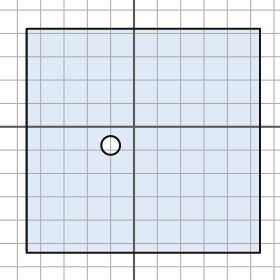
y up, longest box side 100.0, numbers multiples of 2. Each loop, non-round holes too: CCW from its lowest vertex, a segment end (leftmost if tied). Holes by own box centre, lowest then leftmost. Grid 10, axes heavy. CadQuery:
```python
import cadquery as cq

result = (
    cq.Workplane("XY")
    .moveTo(-46.0, -54.0)
    .lineTo(54.0, -54.0)
    .lineTo(54.0, 42.0)
    .lineTo(-46.0, 42.0)
    .close()
    .moveTo(-10.0, -8.0)
    .circle(4.0)
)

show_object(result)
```